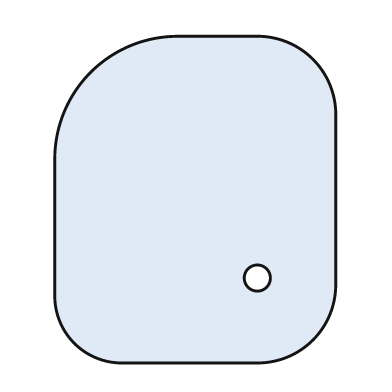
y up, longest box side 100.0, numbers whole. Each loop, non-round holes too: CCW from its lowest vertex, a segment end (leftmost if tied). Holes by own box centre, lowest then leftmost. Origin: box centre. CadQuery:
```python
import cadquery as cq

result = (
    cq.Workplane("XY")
    .moveTo(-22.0, -50.0)
    .lineTo(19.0, -50.0)
    .threePointArc((36.0, -43.0), (43.0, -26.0))
    .lineTo(43.0, 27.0)
    .threePointArc((36.0, 43.0), (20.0, 50.0))
    .lineTo(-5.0, 50.0)
    .threePointArc((-32.0, 39.0), (-43.0, 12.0))
    .lineTo(-43.0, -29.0)
    .threePointArc((-37.0, -44.0), (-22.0, -50.0))
    .close()
    .moveTo(19.0, -24.0)
    .circle(4.0)
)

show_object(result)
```